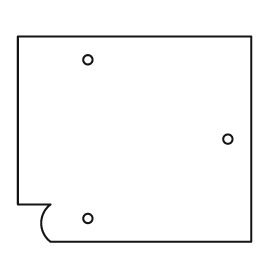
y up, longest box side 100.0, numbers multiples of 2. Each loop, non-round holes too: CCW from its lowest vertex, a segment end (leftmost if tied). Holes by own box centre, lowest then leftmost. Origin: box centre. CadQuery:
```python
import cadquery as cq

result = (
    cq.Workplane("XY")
    .moveTo(-36.0, -44.0)
    .lineTo(50.0, -44.0)
    .lineTo(50.0, 44.0)
    .lineTo(-50.0, 44.0)
    .lineTo(-50.0, -28.0)
    .lineTo(-36.0, -28.0)
    .threePointArc((-40.0, -36.0), (-36.0, -44.0))
    .close()
    .moveTo(-20.0, -34.0)
    .circle(2.0)
    .moveTo(40.0, 0.0)
    .circle(2.0)
    .moveTo(-20.0, 34.0)
    .circle(2.0)
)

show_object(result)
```